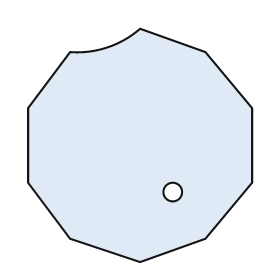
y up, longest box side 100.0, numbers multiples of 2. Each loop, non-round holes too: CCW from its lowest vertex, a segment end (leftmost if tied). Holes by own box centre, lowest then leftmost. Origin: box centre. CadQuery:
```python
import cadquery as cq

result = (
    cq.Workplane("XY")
    .moveTo(0.0, -50.0)
    .lineTo(28.0, -40.0)
    .lineTo(48.0, -16.0)
    .lineTo(48.0, 16.0)
    .lineTo(28.0, 40.0)
    .lineTo(0.0, 50.0)
    .threePointArc((-14.0, 42.0), (-30.0, 40.0))
    .lineTo(-48.0, 16.0)
    .lineTo(-48.0, -16.0)
    .lineTo(-30.0, -40.0)
    .close()
    .moveTo(14.0, -20.0)
    .circle(4.0)
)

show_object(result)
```